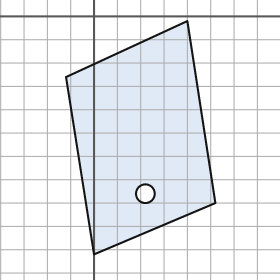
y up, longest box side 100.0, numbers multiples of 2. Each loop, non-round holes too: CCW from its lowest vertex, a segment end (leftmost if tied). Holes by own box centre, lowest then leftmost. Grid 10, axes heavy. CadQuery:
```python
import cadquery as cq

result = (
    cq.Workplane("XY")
    .moveTo(0.0, -102.0)
    .lineTo(52.0, -80.0)
    .lineTo(40.0, -2.0)
    .lineTo(-12.0, -26.0)
    .close()
    .moveTo(22.0, -76.0)
    .circle(4.0)
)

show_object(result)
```